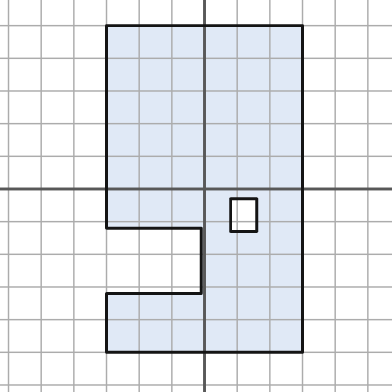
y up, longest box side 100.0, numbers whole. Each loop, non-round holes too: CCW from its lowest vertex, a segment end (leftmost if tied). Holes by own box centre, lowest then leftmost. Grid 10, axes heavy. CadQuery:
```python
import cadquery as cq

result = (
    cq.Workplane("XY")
    .moveTo(-30.0, -50.0)
    .lineTo(30.0, -50.0)
    .lineTo(30.0, 50.0)
    .lineTo(-30.0, 50.0)
    .lineTo(-30.0, -12.0)
    .lineTo(-1.0, -12.0)
    .lineTo(-1.0, -32.0)
    .lineTo(-30.0, -32.0)
    .close()
    .moveTo(8.0, -13.0)
    .lineTo(16.0, -13.0)
    .lineTo(16.0, -3.0)
    .lineTo(8.0, -3.0)
    .close()
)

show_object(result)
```